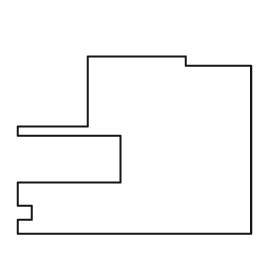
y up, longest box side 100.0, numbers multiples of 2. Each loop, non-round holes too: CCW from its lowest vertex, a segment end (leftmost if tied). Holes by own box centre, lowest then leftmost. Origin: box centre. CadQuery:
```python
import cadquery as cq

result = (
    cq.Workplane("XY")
    .moveTo(-50.0, -38.0)
    .lineTo(50.0, -38.0)
    .lineTo(50.0, 34.0)
    .lineTo(22.0, 34.0)
    .lineTo(22.0, 38.0)
    .lineTo(-20.0, 38.0)
    .lineTo(-20.0, 8.0)
    .lineTo(-50.0, 8.0)
    .lineTo(-50.0, 4.0)
    .lineTo(-6.0, 4.0)
    .lineTo(-6.0, -16.0)
    .lineTo(-50.0, -16.0)
    .lineTo(-50.0, -26.0)
    .lineTo(-44.0, -26.0)
    .lineTo(-44.0, -32.0)
    .lineTo(-50.0, -32.0)
    .close()
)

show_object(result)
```